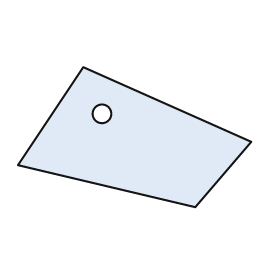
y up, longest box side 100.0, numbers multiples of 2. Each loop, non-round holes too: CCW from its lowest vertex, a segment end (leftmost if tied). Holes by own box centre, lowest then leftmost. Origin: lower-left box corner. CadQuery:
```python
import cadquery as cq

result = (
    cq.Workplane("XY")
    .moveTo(76.0, 0.0)
    .lineTo(100.0, 28.0)
    .lineTo(28.0, 60.0)
    .lineTo(0.0, 18.0)
    .close()
    .moveTo(36.0, 40.0)
    .circle(4.0)
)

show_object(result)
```